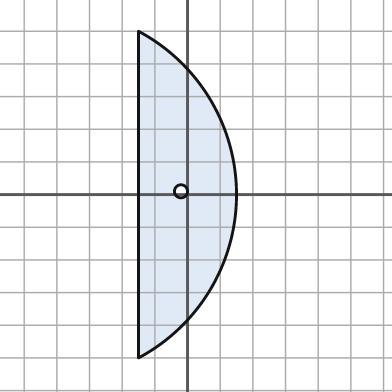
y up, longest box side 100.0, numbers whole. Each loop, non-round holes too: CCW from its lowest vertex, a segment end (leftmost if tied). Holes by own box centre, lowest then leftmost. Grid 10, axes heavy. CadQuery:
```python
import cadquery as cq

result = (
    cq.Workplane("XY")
    .moveTo(-15.0, -50.0)
    .threePointArc((15.0, 0.0), (-15.0, 50.0))
    .close()
    .moveTo(-2.0, 1.0)
    .circle(2.0)
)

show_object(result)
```